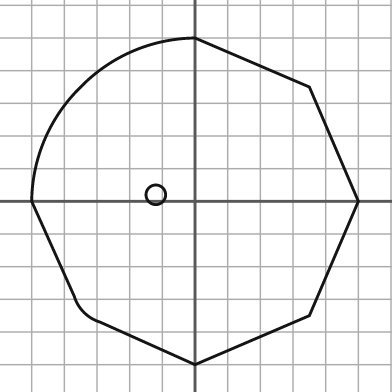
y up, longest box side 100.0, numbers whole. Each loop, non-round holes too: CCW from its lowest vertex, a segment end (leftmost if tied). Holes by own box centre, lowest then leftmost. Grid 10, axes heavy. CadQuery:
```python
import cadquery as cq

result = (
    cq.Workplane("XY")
    .moveTo(0.0, -50.0)
    .lineTo(35.0, -35.0)
    .lineTo(50.0, 0.0)
    .lineTo(35.0, 35.0)
    .lineTo(0.0, 50.0)
    .threePointArc((-19.0, 46.0), (-35.0, 35.0))
    .threePointArc((-46.0, 19.0), (-50.0, 0.0))
    .lineTo(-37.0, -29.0)
    .threePointArc((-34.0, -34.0), (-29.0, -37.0))
    .close()
    .moveTo(-12.0, 2.0)
    .circle(3.0)
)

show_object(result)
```